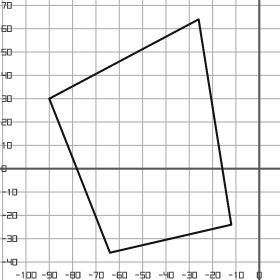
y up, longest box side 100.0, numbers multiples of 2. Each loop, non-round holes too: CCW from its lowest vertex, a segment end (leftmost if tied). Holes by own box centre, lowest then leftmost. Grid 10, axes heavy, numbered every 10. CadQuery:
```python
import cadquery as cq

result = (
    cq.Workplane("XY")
    .moveTo(-64.0, -36.0)
    .lineTo(-12.0, -24.0)
    .lineTo(-26.0, 64.0)
    .lineTo(-90.0, 30.0)
    .close()
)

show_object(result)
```